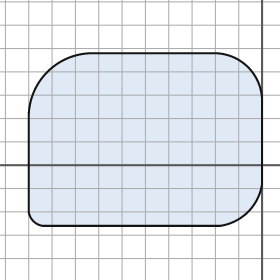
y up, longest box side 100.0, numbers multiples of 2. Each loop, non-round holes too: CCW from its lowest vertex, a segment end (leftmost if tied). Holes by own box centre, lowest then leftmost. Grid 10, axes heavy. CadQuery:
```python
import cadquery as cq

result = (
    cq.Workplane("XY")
    .moveTo(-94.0, -26.0)
    .lineTo(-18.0, -26.0)
    .threePointArc((-6.0, -20.0), (0.0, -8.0))
    .lineTo(0.0, 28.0)
    .threePointArc((-6.0, 42.0), (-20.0, 48.0))
    .lineTo(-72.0, 48.0)
    .threePointArc((-92.0, 40.0), (-100.0, 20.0))
    .lineTo(-100.0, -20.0)
    .threePointArc((-98.0, -24.0), (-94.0, -26.0))
    .close()
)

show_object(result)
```